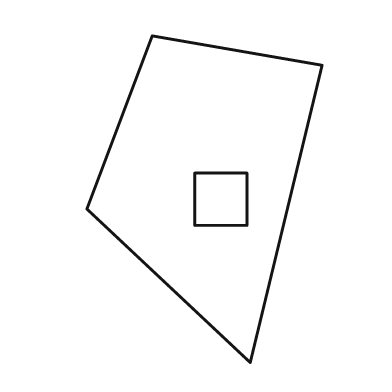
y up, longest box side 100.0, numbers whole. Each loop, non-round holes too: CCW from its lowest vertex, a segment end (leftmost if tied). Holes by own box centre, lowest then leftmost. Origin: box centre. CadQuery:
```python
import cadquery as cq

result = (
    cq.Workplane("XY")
    .moveTo(14.0, -50.0)
    .lineTo(36.0, 41.0)
    .lineTo(-16.0, 50.0)
    .lineTo(-36.0, -3.0)
    .close()
    .moveTo(-3.0, -8.0)
    .lineTo(13.0, -8.0)
    .lineTo(13.0, 8.0)
    .lineTo(-3.0, 8.0)
    .close()
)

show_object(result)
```